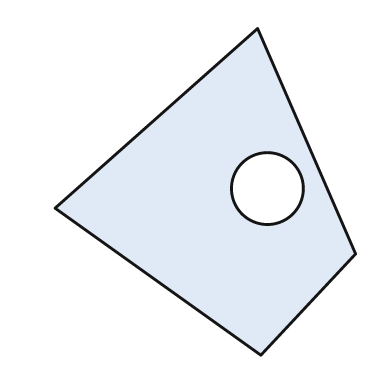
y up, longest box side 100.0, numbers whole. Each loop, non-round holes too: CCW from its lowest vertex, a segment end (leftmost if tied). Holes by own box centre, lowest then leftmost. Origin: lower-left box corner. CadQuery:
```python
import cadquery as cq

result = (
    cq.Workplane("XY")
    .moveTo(63.0, 0.0)
    .lineTo(92.0, 31.0)
    .lineTo(62.0, 100.0)
    .lineTo(0.0, 45.0)
    .close()
    .moveTo(65.0, 51.0)
    .circle(11.0)
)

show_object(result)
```